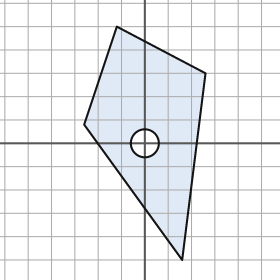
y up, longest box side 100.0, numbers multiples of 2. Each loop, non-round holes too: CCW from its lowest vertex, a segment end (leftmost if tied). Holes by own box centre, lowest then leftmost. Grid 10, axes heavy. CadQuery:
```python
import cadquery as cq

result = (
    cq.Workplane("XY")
    .moveTo(16.0, -50.0)
    .lineTo(26.0, 30.0)
    .lineTo(-12.0, 50.0)
    .lineTo(-26.0, 8.0)
    .close()
    .moveTo(0.0, 0.0)
    .circle(6.0)
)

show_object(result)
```